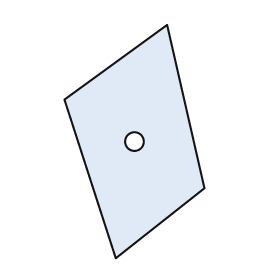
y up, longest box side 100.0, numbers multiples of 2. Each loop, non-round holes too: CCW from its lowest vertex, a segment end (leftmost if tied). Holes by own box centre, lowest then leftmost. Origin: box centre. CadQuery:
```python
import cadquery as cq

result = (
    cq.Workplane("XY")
    .moveTo(-8.0, -50.0)
    .lineTo(30.0, -20.0)
    .lineTo(14.0, 50.0)
    .lineTo(-30.0, 18.0)
    .close()
    .moveTo(0.0, 0.0)
    .circle(4.0)
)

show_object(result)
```